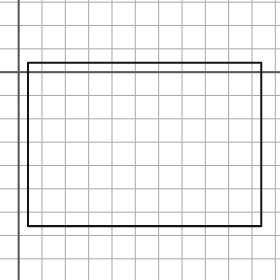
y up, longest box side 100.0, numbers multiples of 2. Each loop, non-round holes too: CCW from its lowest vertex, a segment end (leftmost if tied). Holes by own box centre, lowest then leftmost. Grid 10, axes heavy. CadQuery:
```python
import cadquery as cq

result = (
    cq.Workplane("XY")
    .moveTo(4.0, -66.0)
    .lineTo(104.0, -66.0)
    .lineTo(104.0, 4.0)
    .lineTo(4.0, 4.0)
    .close()
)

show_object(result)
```